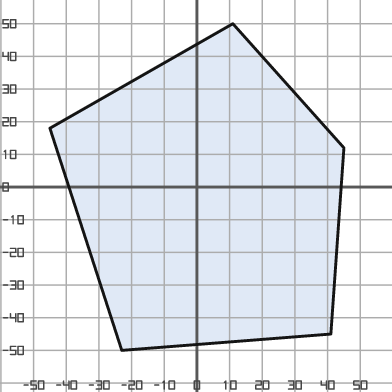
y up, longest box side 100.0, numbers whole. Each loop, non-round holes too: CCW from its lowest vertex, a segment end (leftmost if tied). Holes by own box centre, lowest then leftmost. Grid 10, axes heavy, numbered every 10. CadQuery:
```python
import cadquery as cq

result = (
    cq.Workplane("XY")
    .moveTo(-23.0, -50.0)
    .lineTo(41.0, -45.0)
    .lineTo(45.0, 12.0)
    .lineTo(11.0, 50.0)
    .lineTo(-45.0, 18.0)
    .close()
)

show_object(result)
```